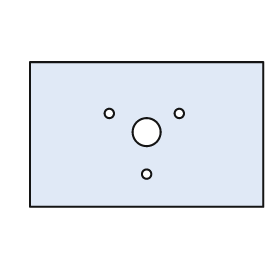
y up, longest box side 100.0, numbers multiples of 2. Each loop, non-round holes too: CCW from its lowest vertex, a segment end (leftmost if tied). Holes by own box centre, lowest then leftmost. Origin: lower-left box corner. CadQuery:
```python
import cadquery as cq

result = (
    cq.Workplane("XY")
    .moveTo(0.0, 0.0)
    .lineTo(100.0, 0.0)
    .lineTo(100.0, 62.0)
    .lineTo(0.0, 62.0)
    .close()
    .moveTo(50.0, 14.0)
    .circle(2.0)
    .moveTo(50.0, 32.0)
    .circle(6.0)
    .moveTo(34.0, 40.0)
    .circle(2.0)
    .moveTo(64.0, 40.0)
    .circle(2.0)
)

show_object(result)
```